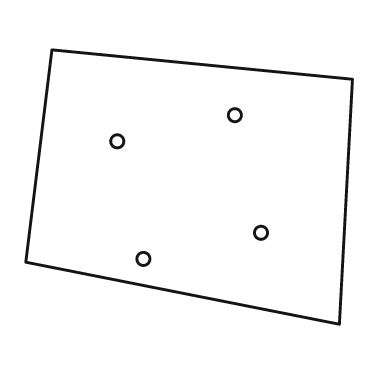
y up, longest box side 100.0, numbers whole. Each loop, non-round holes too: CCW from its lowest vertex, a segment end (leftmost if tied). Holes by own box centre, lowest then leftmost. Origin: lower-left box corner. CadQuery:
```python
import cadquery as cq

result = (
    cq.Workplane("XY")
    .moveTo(96.0, 0.0)
    .lineTo(100.0, 75.0)
    .lineTo(8.0, 84.0)
    .lineTo(0.0, 19.0)
    .close()
    .moveTo(36.0, 20.0)
    .circle(2.0)
    .moveTo(72.0, 28.0)
    .circle(2.0)
    .moveTo(28.0, 56.0)
    .circle(2.0)
    .moveTo(64.0, 64.0)
    .circle(2.0)
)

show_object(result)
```